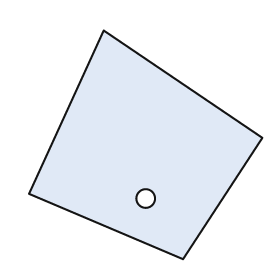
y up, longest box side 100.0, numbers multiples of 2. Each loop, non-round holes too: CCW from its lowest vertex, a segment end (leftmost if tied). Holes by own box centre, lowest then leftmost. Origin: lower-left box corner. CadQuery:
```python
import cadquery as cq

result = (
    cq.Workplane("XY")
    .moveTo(66.0, 0.0)
    .lineTo(100.0, 52.0)
    .lineTo(32.0, 98.0)
    .lineTo(0.0, 28.0)
    .close()
    .moveTo(50.0, 26.0)
    .circle(4.0)
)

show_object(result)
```